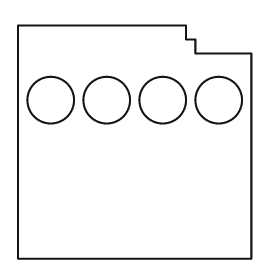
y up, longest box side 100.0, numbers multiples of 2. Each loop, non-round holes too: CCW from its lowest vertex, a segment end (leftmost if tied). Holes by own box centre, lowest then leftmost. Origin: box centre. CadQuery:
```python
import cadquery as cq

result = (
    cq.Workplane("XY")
    .moveTo(-50.0, -50.0)
    .lineTo(50.0, -50.0)
    .lineTo(50.0, 38.0)
    .lineTo(26.0, 38.0)
    .lineTo(26.0, 44.0)
    .lineTo(22.0, 44.0)
    .lineTo(22.0, 50.0)
    .lineTo(-50.0, 50.0)
    .close()
    .moveTo(-36.0, 18.0)
    .circle(10.0)
    .moveTo(-12.0, 18.0)
    .circle(10.0)
    .moveTo(12.0, 18.0)
    .circle(10.0)
    .moveTo(36.0, 18.0)
    .circle(10.0)
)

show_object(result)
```